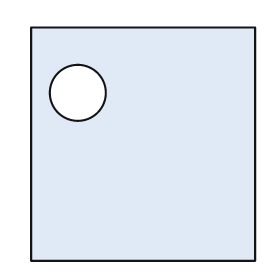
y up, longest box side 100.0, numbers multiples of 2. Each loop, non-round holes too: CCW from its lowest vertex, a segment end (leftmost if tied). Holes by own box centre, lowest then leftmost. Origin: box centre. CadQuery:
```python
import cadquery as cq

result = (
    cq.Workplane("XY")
    .moveTo(-48.0, -50.0)
    .lineTo(48.0, -50.0)
    .lineTo(48.0, 50.0)
    .lineTo(-48.0, 50.0)
    .close()
    .moveTo(-28.0, 22.0)
    .circle(12.0)
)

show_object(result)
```